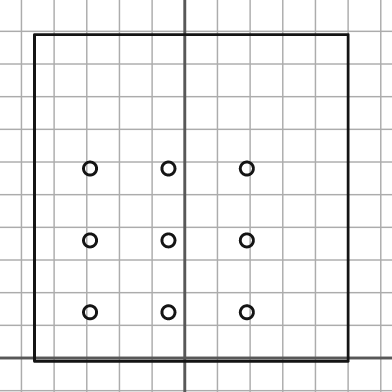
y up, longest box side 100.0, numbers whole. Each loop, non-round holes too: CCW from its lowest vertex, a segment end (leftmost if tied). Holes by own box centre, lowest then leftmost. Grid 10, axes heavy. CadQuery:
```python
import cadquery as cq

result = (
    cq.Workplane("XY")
    .moveTo(-46.0, -1.0)
    .lineTo(50.0, -1.0)
    .lineTo(50.0, 99.0)
    .lineTo(-46.0, 99.0)
    .close()
    .moveTo(-29.0, 14.0)
    .circle(2.0)
    .moveTo(-5.0, 14.0)
    .circle(2.0)
    .moveTo(19.0, 14.0)
    .circle(2.0)
    .moveTo(-29.0, 36.0)
    .circle(2.0)
    .moveTo(-5.0, 36.0)
    .circle(2.0)
    .moveTo(19.0, 36.0)
    .circle(2.0)
    .moveTo(-29.0, 58.0)
    .circle(2.0)
    .moveTo(-5.0, 58.0)
    .circle(2.0)
    .moveTo(19.0, 58.0)
    .circle(2.0)
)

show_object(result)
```